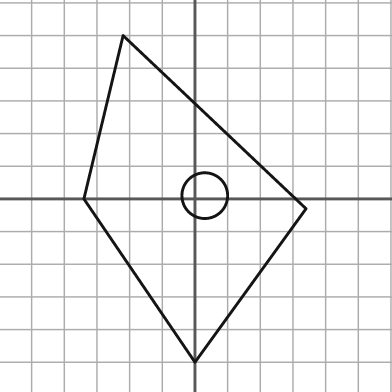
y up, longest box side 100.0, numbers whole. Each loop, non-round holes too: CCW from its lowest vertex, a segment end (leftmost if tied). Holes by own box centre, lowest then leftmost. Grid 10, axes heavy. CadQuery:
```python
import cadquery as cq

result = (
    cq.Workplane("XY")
    .moveTo(0.0, -50.0)
    .lineTo(34.0, -3.0)
    .lineTo(-22.0, 50.0)
    .lineTo(-34.0, 0.0)
    .close()
    .moveTo(3.0, 1.0)
    .circle(7.0)
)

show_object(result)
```